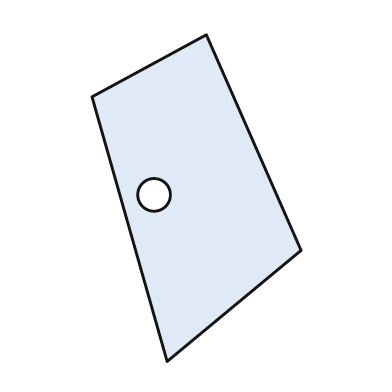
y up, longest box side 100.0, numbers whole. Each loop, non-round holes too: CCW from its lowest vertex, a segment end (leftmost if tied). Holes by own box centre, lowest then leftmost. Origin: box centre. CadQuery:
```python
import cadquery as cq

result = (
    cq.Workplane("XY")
    .moveTo(-9.0, -50.0)
    .lineTo(32.0, -16.0)
    .lineTo(3.0, 50.0)
    .lineTo(-32.0, 31.0)
    .close()
    .moveTo(-13.0, 1.0)
    .circle(5.0)
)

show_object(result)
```